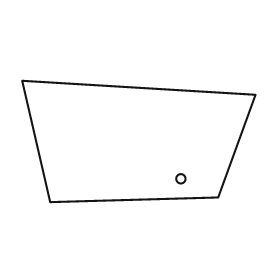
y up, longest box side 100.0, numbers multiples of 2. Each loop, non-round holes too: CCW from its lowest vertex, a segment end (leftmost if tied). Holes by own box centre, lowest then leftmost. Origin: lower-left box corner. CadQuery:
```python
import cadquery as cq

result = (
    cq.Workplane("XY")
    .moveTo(12.0, 0.0)
    .lineTo(84.0, 2.0)
    .lineTo(100.0, 46.0)
    .lineTo(0.0, 52.0)
    .close()
    .moveTo(68.0, 10.0)
    .circle(2.0)
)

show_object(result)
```